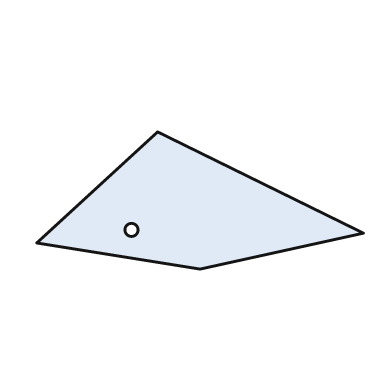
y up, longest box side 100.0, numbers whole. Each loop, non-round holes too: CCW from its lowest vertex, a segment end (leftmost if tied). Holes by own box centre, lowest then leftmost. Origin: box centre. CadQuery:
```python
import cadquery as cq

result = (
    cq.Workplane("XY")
    .moveTo(0.0, -21.0)
    .lineTo(50.0, -10.0)
    .lineTo(-13.0, 21.0)
    .lineTo(-50.0, -13.0)
    .close()
    .moveTo(-21.0, -9.0)
    .circle(2.0)
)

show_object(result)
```